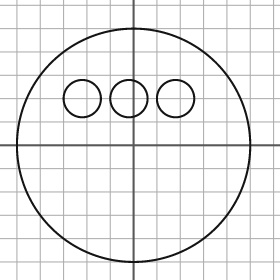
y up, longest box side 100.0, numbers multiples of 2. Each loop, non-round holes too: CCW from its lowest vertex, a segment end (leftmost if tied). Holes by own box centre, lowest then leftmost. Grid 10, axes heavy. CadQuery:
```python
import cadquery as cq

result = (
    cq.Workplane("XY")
    .moveTo(0.0, 0.0)
    .circle(50.0)
    .moveTo(-22.0, 20.0)
    .circle(8.0)
    .moveTo(-2.0, 20.0)
    .circle(8.0)
    .moveTo(18.0, 20.0)
    .circle(8.0)
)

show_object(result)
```